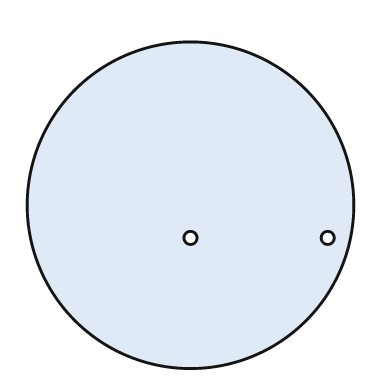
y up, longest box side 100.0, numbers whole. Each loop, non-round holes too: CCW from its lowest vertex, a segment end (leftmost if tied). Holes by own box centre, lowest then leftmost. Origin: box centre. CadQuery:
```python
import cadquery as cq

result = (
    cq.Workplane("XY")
    .moveTo(0.0, 0.0)
    .circle(50.0)
    .moveTo(0.0, -10.0)
    .circle(2.0)
    .moveTo(42.0, -10.0)
    .circle(2.0)
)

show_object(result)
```